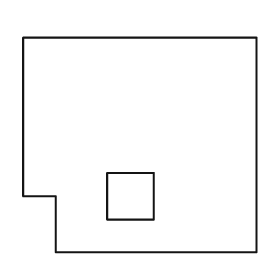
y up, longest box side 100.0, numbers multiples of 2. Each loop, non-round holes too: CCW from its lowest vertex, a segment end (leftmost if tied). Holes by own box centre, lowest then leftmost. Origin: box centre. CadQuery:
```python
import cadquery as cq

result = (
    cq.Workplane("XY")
    .moveTo(-36.0, -46.0)
    .lineTo(50.0, -46.0)
    .lineTo(50.0, 46.0)
    .lineTo(-50.0, 46.0)
    .lineTo(-50.0, -22.0)
    .lineTo(-36.0, -22.0)
    .close()
    .moveTo(-14.0, -32.0)
    .lineTo(6.0, -32.0)
    .lineTo(6.0, -12.0)
    .lineTo(-14.0, -12.0)
    .close()
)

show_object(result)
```